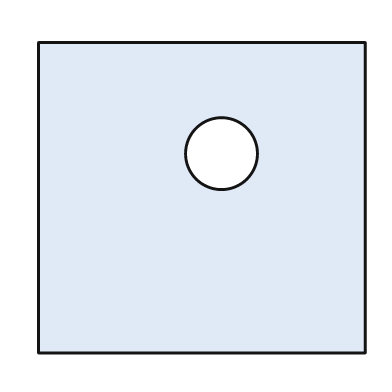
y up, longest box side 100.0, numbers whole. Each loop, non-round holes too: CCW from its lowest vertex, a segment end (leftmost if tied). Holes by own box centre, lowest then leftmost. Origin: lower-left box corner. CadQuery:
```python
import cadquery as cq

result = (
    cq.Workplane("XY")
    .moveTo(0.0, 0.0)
    .lineTo(100.0, 0.0)
    .lineTo(100.0, 95.0)
    .lineTo(0.0, 95.0)
    .close()
    .moveTo(56.0, 61.0)
    .circle(11.0)
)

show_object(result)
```